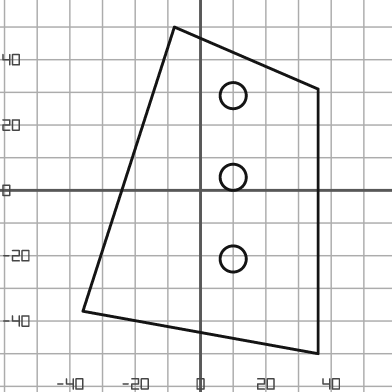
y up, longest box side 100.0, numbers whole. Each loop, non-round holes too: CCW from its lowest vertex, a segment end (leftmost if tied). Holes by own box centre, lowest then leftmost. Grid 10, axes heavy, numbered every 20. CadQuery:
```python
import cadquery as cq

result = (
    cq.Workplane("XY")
    .moveTo(36.0, -50.0)
    .lineTo(36.0, 31.0)
    .lineTo(-8.0, 50.0)
    .lineTo(-36.0, -37.0)
    .close()
    .moveTo(10.0, -21.0)
    .circle(4.0)
    .moveTo(10.0, 4.0)
    .circle(4.0)
    .moveTo(10.0, 29.0)
    .circle(4.0)
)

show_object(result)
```